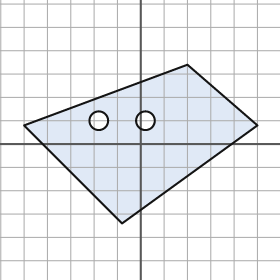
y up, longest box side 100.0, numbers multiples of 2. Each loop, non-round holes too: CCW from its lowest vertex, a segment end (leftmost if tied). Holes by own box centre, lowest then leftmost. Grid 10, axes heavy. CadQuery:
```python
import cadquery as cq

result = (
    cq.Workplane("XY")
    .moveTo(-8.0, -34.0)
    .lineTo(50.0, 8.0)
    .lineTo(20.0, 34.0)
    .lineTo(-50.0, 8.0)
    .close()
    .moveTo(-18.0, 10.0)
    .circle(4.0)
    .moveTo(2.0, 10.0)
    .circle(4.0)
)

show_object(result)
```